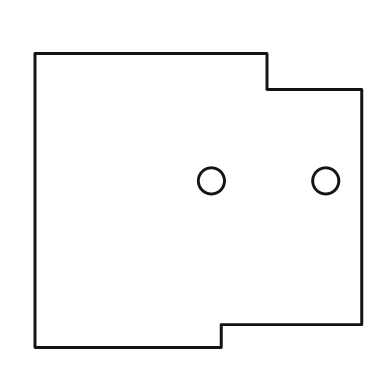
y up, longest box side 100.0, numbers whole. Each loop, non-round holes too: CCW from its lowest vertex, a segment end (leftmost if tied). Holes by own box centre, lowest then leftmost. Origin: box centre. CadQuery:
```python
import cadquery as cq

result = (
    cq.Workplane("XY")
    .moveTo(-50.0, -45.0)
    .lineTo(7.0, -45.0)
    .lineTo(7.0, -38.0)
    .lineTo(50.0, -38.0)
    .lineTo(50.0, 34.0)
    .lineTo(21.0, 34.0)
    .lineTo(21.0, 45.0)
    .lineTo(-50.0, 45.0)
    .close()
    .moveTo(4.0, 6.0)
    .circle(4.0)
    .moveTo(39.0, 6.0)
    .circle(4.0)
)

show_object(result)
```